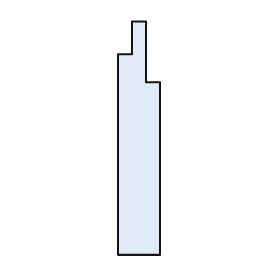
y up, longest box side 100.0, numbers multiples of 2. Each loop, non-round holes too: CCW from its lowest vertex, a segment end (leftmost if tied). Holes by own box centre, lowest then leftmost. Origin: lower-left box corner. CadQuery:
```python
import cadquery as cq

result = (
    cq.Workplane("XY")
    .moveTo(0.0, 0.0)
    .lineTo(18.0, 0.0)
    .lineTo(18.0, 74.0)
    .lineTo(12.0, 74.0)
    .lineTo(12.0, 100.0)
    .lineTo(6.0, 100.0)
    .lineTo(6.0, 86.0)
    .lineTo(0.0, 86.0)
    .close()
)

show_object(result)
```